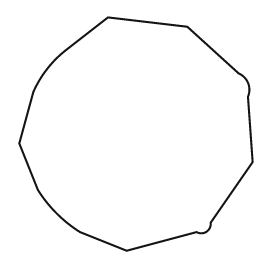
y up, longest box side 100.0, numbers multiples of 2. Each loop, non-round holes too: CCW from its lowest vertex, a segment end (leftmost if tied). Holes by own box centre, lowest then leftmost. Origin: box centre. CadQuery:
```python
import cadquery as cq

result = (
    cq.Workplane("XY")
    .moveTo(-4.0, -50.0)
    .lineTo(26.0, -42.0)
    .threePointArc((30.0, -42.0), (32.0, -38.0))
    .lineTo(50.0, -12.0)
    .lineTo(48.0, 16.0)
    .threePointArc((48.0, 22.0), (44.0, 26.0))
    .lineTo(22.0, 46.0)
    .lineTo(-12.0, 50.0)
    .lineTo(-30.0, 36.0)
    .threePointArc((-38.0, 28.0), (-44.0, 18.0))
    .lineTo(-50.0, -4.0)
    .lineTo(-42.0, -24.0)
    .threePointArc((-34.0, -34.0), (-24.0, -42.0))
    .close()
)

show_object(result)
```